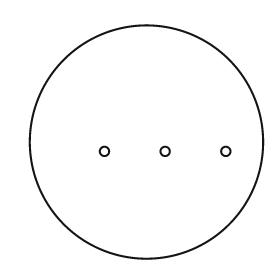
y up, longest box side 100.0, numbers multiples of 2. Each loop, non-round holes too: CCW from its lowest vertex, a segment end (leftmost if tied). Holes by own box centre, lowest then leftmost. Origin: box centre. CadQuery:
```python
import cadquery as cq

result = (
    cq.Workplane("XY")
    .moveTo(0.0, 0.0)
    .circle(50.0)
    .moveTo(-18.0, -4.0)
    .circle(2.0)
    .moveTo(8.0, -4.0)
    .circle(2.0)
    .moveTo(34.0, -4.0)
    .circle(2.0)
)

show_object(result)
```